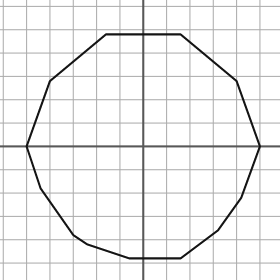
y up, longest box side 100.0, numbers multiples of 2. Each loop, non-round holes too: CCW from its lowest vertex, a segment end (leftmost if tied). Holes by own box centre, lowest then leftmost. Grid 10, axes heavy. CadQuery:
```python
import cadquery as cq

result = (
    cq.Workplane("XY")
    .moveTo(-6.0, -48.0)
    .lineTo(16.0, -48.0)
    .lineTo(32.0, -36.0)
    .lineTo(42.0, -22.0)
    .lineTo(50.0, 0.0)
    .lineTo(40.0, 28.0)
    .lineTo(16.0, 48.0)
    .lineTo(-16.0, 48.0)
    .lineTo(-40.0, 28.0)
    .lineTo(-50.0, 0.0)
    .lineTo(-44.0, -18.0)
    .lineTo(-30.0, -38.0)
    .lineTo(-24.0, -42.0)
    .close()
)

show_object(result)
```